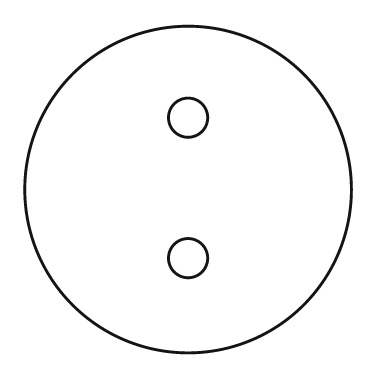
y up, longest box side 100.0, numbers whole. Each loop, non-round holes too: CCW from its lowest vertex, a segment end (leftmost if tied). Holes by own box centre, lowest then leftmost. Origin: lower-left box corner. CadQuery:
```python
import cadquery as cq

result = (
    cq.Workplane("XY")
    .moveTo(50.0, 50.0)
    .circle(50.0)
    .moveTo(50.0, 29.0)
    .circle(6.0)
    .moveTo(50.0, 72.0)
    .circle(6.0)
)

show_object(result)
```